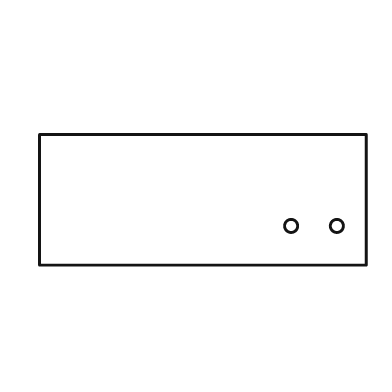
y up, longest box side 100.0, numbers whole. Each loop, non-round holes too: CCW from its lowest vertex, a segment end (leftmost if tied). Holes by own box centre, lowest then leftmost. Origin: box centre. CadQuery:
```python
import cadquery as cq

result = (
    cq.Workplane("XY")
    .moveTo(-50.0, -20.0)
    .lineTo(50.0, -20.0)
    .lineTo(50.0, 20.0)
    .lineTo(-50.0, 20.0)
    .close()
    .moveTo(27.0, -8.0)
    .circle(2.0)
    .moveTo(41.0, -8.0)
    .circle(2.0)
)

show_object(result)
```